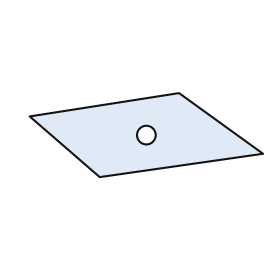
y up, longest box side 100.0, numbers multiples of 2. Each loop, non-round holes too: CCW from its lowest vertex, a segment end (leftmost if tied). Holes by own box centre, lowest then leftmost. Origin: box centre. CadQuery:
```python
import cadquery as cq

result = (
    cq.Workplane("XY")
    .moveTo(-20.0, -18.0)
    .lineTo(50.0, -8.0)
    .lineTo(14.0, 18.0)
    .lineTo(-50.0, 8.0)
    .close()
    .moveTo(0.0, 0.0)
    .circle(4.0)
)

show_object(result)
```